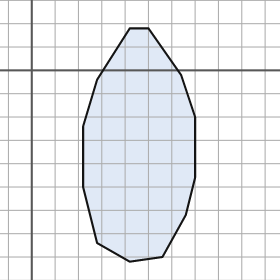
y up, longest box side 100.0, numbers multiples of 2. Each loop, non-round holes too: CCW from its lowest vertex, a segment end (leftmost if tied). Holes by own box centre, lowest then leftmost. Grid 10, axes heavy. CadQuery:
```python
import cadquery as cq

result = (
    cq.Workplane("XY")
    .moveTo(42.0, -82.0)
    .lineTo(56.0, -80.0)
    .lineTo(66.0, -62.0)
    .lineTo(70.0, -46.0)
    .lineTo(70.0, -20.0)
    .lineTo(64.0, -2.0)
    .lineTo(50.0, 18.0)
    .lineTo(42.0, 18.0)
    .lineTo(28.0, -4.0)
    .lineTo(22.0, -24.0)
    .lineTo(22.0, -50.0)
    .lineTo(28.0, -74.0)
    .close()
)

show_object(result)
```